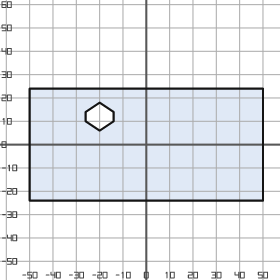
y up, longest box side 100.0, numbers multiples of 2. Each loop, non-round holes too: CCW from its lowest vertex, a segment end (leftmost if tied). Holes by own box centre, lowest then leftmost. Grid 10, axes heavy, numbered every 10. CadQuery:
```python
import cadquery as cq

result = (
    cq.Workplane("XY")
    .moveTo(-50.0, -24.0)
    .lineTo(50.0, -24.0)
    .lineTo(50.0, 24.0)
    .lineTo(-50.0, 24.0)
    .close()
    .moveTo(-20.0, 6.0)
    .lineTo(-14.0, 10.0)
    .lineTo(-14.0, 14.0)
    .lineTo(-20.0, 18.0)
    .lineTo(-26.0, 14.0)
    .lineTo(-26.0, 10.0)
    .close()
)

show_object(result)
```